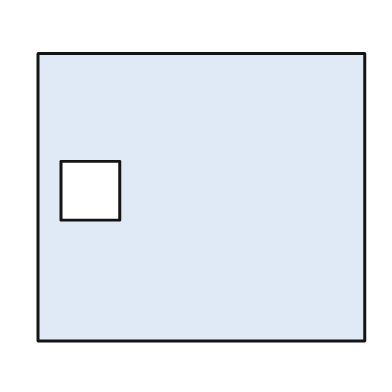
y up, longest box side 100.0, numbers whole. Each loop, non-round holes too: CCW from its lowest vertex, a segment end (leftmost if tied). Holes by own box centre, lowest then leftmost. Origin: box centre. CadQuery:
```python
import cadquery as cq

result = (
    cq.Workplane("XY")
    .moveTo(-50.0, -44.0)
    .lineTo(50.0, -44.0)
    .lineTo(50.0, 44.0)
    .lineTo(-50.0, 44.0)
    .close()
    .moveTo(-43.0, -7.0)
    .lineTo(-25.0, -7.0)
    .lineTo(-25.0, 11.0)
    .lineTo(-43.0, 11.0)
    .close()
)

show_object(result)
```